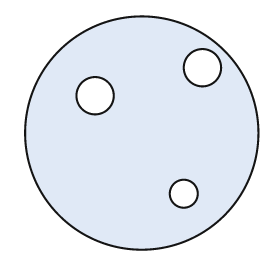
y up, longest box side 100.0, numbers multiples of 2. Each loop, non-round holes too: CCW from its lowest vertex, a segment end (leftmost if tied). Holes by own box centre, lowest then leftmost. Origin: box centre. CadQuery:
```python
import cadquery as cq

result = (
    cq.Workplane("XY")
    .moveTo(0.0, 0.0)
    .circle(50.0)
    .moveTo(18.0, -26.0)
    .circle(6.0)
    .moveTo(-20.0, 16.0)
    .circle(8.0)
    .moveTo(26.0, 28.0)
    .circle(8.0)
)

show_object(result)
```